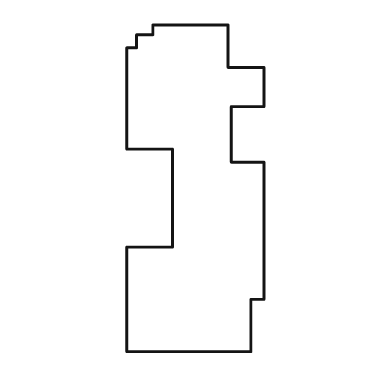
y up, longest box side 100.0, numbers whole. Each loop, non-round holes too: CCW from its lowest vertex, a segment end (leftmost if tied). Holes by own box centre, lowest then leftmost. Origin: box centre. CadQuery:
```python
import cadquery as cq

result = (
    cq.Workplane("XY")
    .moveTo(-21.0, -50.0)
    .lineTo(17.0, -50.0)
    .lineTo(17.0, -34.0)
    .lineTo(21.0, -34.0)
    .lineTo(21.0, 8.0)
    .lineTo(11.0, 8.0)
    .lineTo(11.0, 25.0)
    .lineTo(21.0, 25.0)
    .lineTo(21.0, 37.0)
    .lineTo(10.0, 37.0)
    .lineTo(10.0, 50.0)
    .lineTo(-13.0, 50.0)
    .lineTo(-13.0, 47.0)
    .lineTo(-18.0, 47.0)
    .lineTo(-18.0, 43.0)
    .lineTo(-21.0, 43.0)
    .lineTo(-21.0, 12.0)
    .lineTo(-7.0, 12.0)
    .lineTo(-7.0, -18.0)
    .lineTo(-21.0, -18.0)
    .close()
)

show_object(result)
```